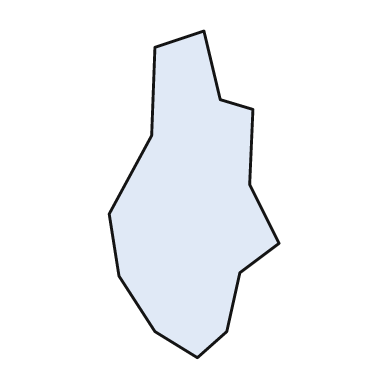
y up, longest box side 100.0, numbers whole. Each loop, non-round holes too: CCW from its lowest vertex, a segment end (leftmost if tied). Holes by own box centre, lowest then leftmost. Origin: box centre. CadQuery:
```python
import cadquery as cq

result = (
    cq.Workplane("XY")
    .moveTo(1.0, -50.0)
    .lineTo(10.0, -42.0)
    .lineTo(14.0, -24.0)
    .lineTo(26.0, -15.0)
    .lineTo(17.0, 3.0)
    .lineTo(18.0, 26.0)
    .lineTo(8.0, 29.0)
    .lineTo(3.0, 50.0)
    .lineTo(-12.0, 45.0)
    .lineTo(-13.0, 18.0)
    .lineTo(-26.0, -6.0)
    .lineTo(-23.0, -25.0)
    .lineTo(-12.0, -42.0)
    .close()
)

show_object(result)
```